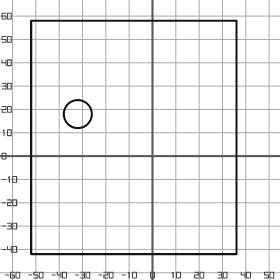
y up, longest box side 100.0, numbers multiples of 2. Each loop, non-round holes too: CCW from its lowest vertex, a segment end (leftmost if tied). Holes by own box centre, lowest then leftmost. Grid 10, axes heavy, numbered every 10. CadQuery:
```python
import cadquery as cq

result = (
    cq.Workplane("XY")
    .moveTo(-52.0, -42.0)
    .lineTo(36.0, -42.0)
    .lineTo(36.0, 58.0)
    .lineTo(-52.0, 58.0)
    .close()
    .moveTo(-32.0, 18.0)
    .circle(6.0)
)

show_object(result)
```